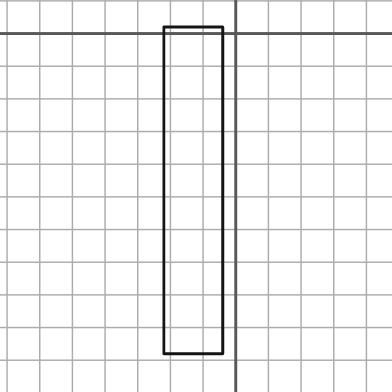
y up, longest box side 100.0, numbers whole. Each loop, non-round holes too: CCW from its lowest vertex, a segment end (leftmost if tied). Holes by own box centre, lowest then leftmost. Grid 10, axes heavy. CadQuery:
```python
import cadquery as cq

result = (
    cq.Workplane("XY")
    .moveTo(-22.0, -98.0)
    .lineTo(-4.0, -98.0)
    .lineTo(-4.0, 2.0)
    .lineTo(-22.0, 2.0)
    .close()
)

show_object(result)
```